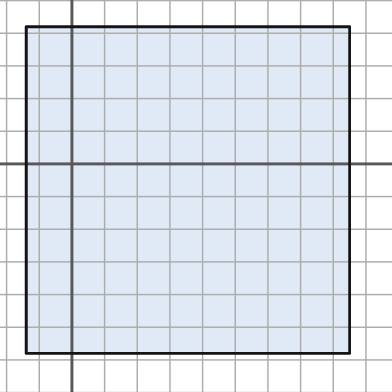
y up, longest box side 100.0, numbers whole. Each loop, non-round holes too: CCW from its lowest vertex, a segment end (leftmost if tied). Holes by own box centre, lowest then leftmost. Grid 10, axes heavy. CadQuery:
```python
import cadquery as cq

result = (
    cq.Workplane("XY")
    .moveTo(-14.0, -58.0)
    .lineTo(85.0, -58.0)
    .lineTo(85.0, 42.0)
    .lineTo(-14.0, 42.0)
    .close()
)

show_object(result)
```